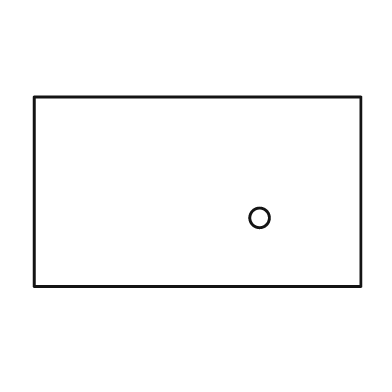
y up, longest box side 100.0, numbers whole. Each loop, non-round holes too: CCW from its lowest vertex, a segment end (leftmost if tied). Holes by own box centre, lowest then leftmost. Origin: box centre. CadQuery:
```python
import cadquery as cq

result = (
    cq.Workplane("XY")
    .moveTo(-50.0, -29.0)
    .lineTo(50.0, -29.0)
    .lineTo(50.0, 29.0)
    .lineTo(-50.0, 29.0)
    .close()
    .moveTo(19.0, -8.0)
    .circle(3.0)
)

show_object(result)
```